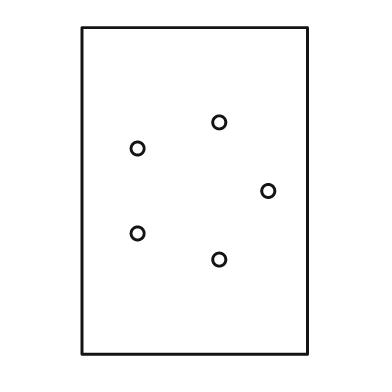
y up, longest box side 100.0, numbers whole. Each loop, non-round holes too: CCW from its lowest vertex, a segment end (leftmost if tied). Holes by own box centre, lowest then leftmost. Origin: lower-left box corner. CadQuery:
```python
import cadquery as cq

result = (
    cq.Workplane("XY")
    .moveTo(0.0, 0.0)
    .lineTo(69.0, 0.0)
    .lineTo(69.0, 100.0)
    .lineTo(0.0, 100.0)
    .close()
    .moveTo(42.0, 29.0)
    .circle(2.0)
    .moveTo(17.0, 37.0)
    .circle(2.0)
    .moveTo(57.0, 50.0)
    .circle(2.0)
    .moveTo(17.0, 63.0)
    .circle(2.0)
    .moveTo(42.0, 71.0)
    .circle(2.0)
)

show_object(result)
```